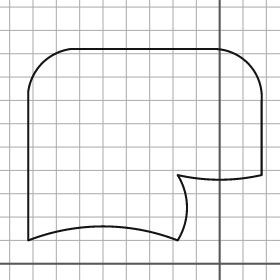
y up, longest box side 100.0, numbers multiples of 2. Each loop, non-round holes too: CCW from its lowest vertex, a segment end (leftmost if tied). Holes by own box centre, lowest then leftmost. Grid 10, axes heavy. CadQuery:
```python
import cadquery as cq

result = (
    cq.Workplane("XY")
    .moveTo(-82.0, 10.0)
    .threePointArc((-50.0, 16.0), (-18.0, 10.0))
    .threePointArc((-14.0, 24.0), (-18.0, 38.0))
    .threePointArc((0.0, 36.0), (18.0, 38.0))
    .lineTo(18.0, 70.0)
    .threePointArc((12.0, 86.0), (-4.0, 92.0))
    .lineTo(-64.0, 92.0)
    .threePointArc((-76.0, 86.0), (-82.0, 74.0))
    .close()
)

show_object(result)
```